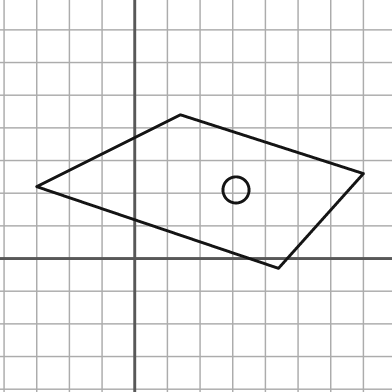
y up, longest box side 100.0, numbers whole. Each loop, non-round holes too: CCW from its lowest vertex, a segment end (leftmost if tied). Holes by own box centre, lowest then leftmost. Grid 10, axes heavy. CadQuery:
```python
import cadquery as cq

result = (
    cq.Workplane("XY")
    .moveTo(44.0, -3.0)
    .lineTo(70.0, 26.0)
    .lineTo(14.0, 44.0)
    .lineTo(-30.0, 22.0)
    .close()
    .moveTo(31.0, 21.0)
    .circle(4.0)
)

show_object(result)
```